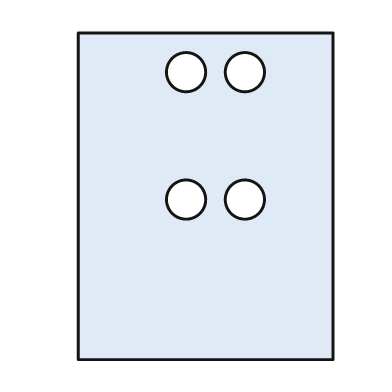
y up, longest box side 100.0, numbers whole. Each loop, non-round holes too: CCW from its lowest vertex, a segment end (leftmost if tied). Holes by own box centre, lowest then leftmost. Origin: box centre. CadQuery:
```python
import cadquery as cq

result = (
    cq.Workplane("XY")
    .moveTo(-39.0, -50.0)
    .lineTo(39.0, -50.0)
    .lineTo(39.0, 50.0)
    .lineTo(-39.0, 50.0)
    .close()
    .moveTo(-6.0, -1.0)
    .circle(6.0)
    .moveTo(12.0, -1.0)
    .circle(6.0)
    .moveTo(-6.0, 38.0)
    .circle(6.0)
    .moveTo(12.0, 38.0)
    .circle(6.0)
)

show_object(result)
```